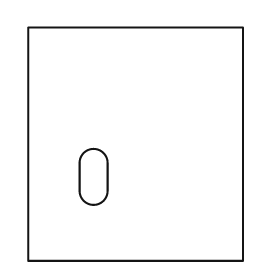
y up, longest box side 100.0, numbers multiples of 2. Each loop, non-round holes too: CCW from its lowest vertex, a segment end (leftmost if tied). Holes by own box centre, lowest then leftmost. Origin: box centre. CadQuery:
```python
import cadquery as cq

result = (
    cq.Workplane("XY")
    .moveTo(-46.0, -50.0)
    .lineTo(46.0, -50.0)
    .lineTo(46.0, 50.0)
    .lineTo(-46.0, 50.0)
    .close()
    .moveTo(-24.0, -20.0)
    .threePointArc((-18.0, -26.0), (-12.0, -20.0))
    .lineTo(-12.0, -8.0)
    .threePointArc((-18.0, -2.0), (-24.0, -8.0))
    .close()
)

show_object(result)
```